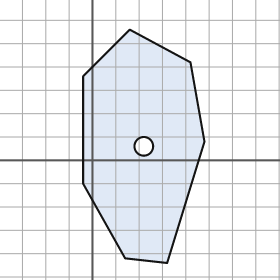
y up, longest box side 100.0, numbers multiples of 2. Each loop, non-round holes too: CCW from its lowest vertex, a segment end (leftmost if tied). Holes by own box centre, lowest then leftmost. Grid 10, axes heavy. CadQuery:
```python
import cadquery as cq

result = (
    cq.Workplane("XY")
    .moveTo(32.0, -44.0)
    .lineTo(48.0, 8.0)
    .lineTo(42.0, 42.0)
    .lineTo(16.0, 56.0)
    .lineTo(-4.0, 36.0)
    .lineTo(-4.0, -10.0)
    .lineTo(14.0, -42.0)
    .close()
    .moveTo(22.0, 6.0)
    .circle(4.0)
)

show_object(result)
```